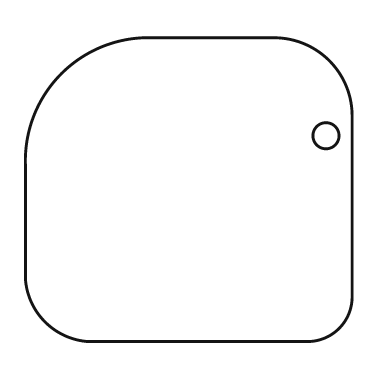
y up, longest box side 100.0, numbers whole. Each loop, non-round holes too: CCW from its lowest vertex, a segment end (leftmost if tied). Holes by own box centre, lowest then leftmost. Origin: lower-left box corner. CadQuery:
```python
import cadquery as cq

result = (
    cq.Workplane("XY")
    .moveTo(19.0, 0.0)
    .lineTo(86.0, 0.0)
    .threePointArc((96.0, 4.0), (100.0, 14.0))
    .lineTo(100.0, 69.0)
    .threePointArc((93.0, 86.0), (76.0, 93.0))
    .lineTo(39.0, 93.0)
    .threePointArc((11.0, 82.0), (0.0, 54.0))
    .lineTo(0.0, 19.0)
    .threePointArc((6.0, 6.0), (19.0, 0.0))
    .close()
    .moveTo(92.0, 63.0)
    .circle(4.0)
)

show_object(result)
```